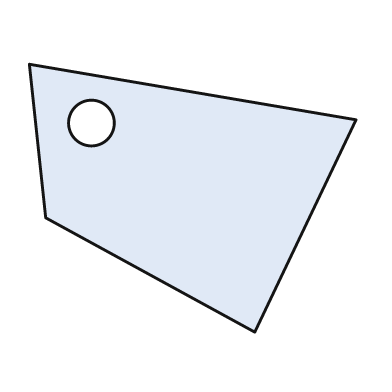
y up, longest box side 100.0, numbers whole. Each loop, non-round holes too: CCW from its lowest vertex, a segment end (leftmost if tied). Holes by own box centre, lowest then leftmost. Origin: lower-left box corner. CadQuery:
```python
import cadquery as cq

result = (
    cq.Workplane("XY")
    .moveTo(69.0, 0.0)
    .lineTo(100.0, 65.0)
    .lineTo(0.0, 82.0)
    .lineTo(5.0, 35.0)
    .close()
    .moveTo(19.0, 64.0)
    .circle(7.0)
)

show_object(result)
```